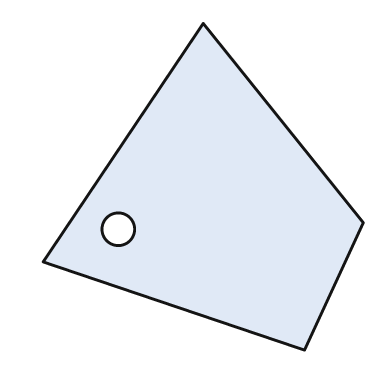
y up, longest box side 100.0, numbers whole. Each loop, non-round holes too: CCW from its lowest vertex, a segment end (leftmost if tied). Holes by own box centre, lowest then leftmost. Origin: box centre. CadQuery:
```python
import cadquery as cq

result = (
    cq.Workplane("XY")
    .moveTo(31.0, -50.0)
    .lineTo(49.0, -11.0)
    .lineTo(0.0, 50.0)
    .lineTo(-49.0, -23.0)
    .close()
    .moveTo(-26.0, -13.0)
    .circle(5.0)
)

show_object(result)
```